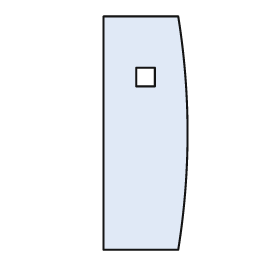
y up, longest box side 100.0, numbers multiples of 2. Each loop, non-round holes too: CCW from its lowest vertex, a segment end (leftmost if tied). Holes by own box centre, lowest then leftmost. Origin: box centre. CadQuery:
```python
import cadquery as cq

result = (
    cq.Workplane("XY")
    .moveTo(-18.0, -50.0)
    .lineTo(14.0, -50.0)
    .threePointArc((18.0, 0.0), (14.0, 50.0))
    .lineTo(-18.0, 50.0)
    .close()
    .moveTo(-4.0, 20.0)
    .lineTo(4.0, 20.0)
    .lineTo(4.0, 28.0)
    .lineTo(-4.0, 28.0)
    .close()
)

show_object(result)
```